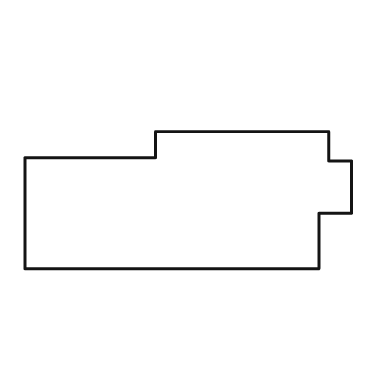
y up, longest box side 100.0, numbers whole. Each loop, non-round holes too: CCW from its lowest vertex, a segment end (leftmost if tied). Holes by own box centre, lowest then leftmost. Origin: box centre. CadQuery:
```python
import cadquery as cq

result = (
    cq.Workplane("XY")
    .moveTo(-50.0, -21.0)
    .lineTo(40.0, -21.0)
    .lineTo(40.0, -4.0)
    .lineTo(50.0, -4.0)
    .lineTo(50.0, 12.0)
    .lineTo(43.0, 12.0)
    .lineTo(43.0, 21.0)
    .lineTo(-10.0, 21.0)
    .lineTo(-10.0, 13.0)
    .lineTo(-50.0, 13.0)
    .close()
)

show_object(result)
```